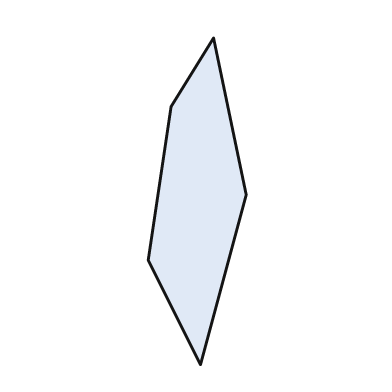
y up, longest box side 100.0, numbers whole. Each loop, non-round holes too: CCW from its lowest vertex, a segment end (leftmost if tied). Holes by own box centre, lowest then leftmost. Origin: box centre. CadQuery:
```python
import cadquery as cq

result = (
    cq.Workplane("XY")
    .moveTo(1.0, -50.0)
    .lineTo(15.0, 2.0)
    .lineTo(5.0, 50.0)
    .lineTo(-8.0, 29.0)
    .lineTo(-15.0, -18.0)
    .close()
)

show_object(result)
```